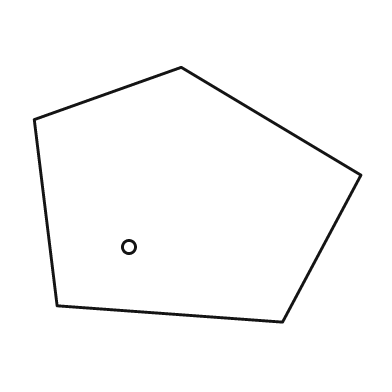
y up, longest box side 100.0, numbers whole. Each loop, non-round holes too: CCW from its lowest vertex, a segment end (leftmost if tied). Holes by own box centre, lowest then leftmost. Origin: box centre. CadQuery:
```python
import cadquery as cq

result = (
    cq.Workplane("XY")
    .moveTo(26.0, -39.0)
    .lineTo(50.0, 6.0)
    .lineTo(-5.0, 39.0)
    .lineTo(-50.0, 23.0)
    .lineTo(-43.0, -34.0)
    .close()
    .moveTo(-21.0, -16.0)
    .circle(2.0)
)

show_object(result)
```